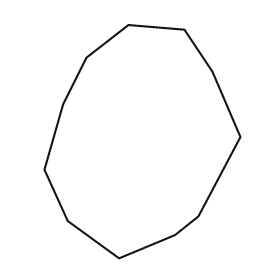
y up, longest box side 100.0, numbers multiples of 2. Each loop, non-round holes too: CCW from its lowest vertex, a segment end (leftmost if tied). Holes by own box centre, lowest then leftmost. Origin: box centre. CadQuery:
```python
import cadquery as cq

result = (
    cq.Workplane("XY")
    .moveTo(-10.0, -50.0)
    .lineTo(14.0, -40.0)
    .lineTo(24.0, -32.0)
    .lineTo(42.0, 2.0)
    .lineTo(30.0, 30.0)
    .lineTo(18.0, 48.0)
    .lineTo(-6.0, 50.0)
    .lineTo(-24.0, 36.0)
    .lineTo(-34.0, 16.0)
    .lineTo(-42.0, -12.0)
    .lineTo(-32.0, -34.0)
    .close()
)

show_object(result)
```